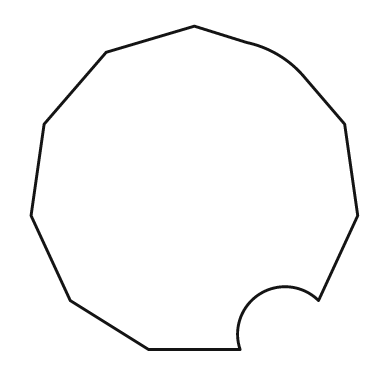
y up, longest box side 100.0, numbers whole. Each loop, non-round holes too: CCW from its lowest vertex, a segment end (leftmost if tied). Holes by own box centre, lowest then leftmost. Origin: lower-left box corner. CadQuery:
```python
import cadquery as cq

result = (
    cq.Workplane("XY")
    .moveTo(36.0, 0.0)
    .lineTo(64.0, 0.0)
    .threePointArc((70.0, 17.0), (88.0, 15.0))
    .lineTo(100.0, 41.0)
    .lineTo(96.0, 69.0)
    .lineTo(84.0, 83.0)
    .threePointArc((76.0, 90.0), (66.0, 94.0))
    .lineTo(50.0, 99.0)
    .lineTo(23.0, 91.0)
    .lineTo(4.0, 69.0)
    .lineTo(0.0, 41.0)
    .lineTo(12.0, 15.0)
    .close()
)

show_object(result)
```